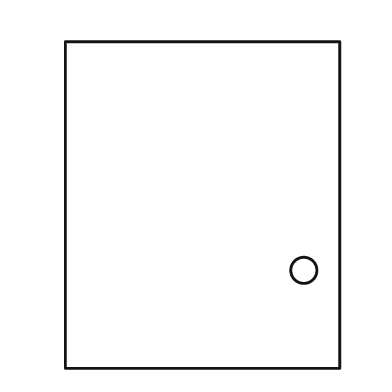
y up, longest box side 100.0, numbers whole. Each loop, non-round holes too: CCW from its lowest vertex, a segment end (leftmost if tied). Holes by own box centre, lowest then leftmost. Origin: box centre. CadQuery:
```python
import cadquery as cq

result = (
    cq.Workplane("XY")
    .moveTo(-42.0, -50.0)
    .lineTo(42.0, -50.0)
    .lineTo(42.0, 50.0)
    .lineTo(-42.0, 50.0)
    .close()
    .moveTo(31.0, -20.0)
    .circle(4.0)
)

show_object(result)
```